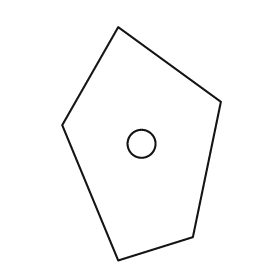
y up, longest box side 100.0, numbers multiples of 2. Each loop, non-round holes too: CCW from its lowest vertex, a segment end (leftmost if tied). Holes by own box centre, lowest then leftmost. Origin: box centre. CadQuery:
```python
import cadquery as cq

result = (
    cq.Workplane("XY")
    .moveTo(-10.0, -50.0)
    .lineTo(22.0, -40.0)
    .lineTo(34.0, 18.0)
    .lineTo(-10.0, 50.0)
    .lineTo(-34.0, 8.0)
    .close()
    .moveTo(0.0, 0.0)
    .circle(6.0)
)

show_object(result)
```